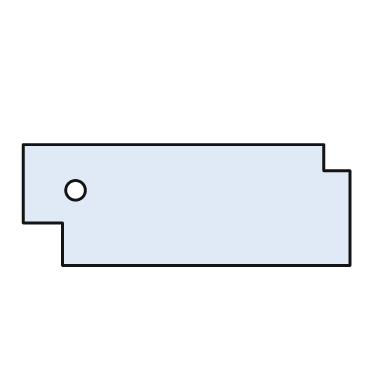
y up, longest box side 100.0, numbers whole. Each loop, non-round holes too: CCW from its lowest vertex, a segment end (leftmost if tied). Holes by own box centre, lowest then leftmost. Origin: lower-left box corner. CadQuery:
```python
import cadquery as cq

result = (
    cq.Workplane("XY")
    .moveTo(12.0, 0.0)
    .lineTo(100.0, 0.0)
    .lineTo(100.0, 29.0)
    .lineTo(92.0, 29.0)
    .lineTo(92.0, 37.0)
    .lineTo(0.0, 37.0)
    .lineTo(0.0, 13.0)
    .lineTo(12.0, 13.0)
    .close()
    .moveTo(16.0, 23.0)
    .circle(3.0)
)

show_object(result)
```